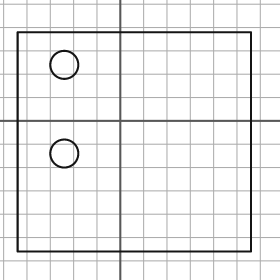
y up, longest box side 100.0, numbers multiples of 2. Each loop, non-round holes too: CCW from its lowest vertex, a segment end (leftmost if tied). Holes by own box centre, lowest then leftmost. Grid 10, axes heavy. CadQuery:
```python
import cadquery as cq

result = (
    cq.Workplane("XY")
    .moveTo(-44.0, -56.0)
    .lineTo(56.0, -56.0)
    .lineTo(56.0, 38.0)
    .lineTo(-44.0, 38.0)
    .close()
    .moveTo(-24.0, -14.0)
    .circle(6.0)
    .moveTo(-24.0, 24.0)
    .circle(6.0)
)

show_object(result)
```